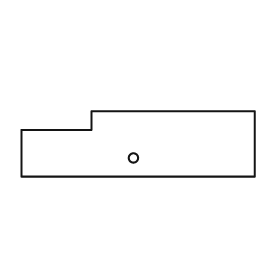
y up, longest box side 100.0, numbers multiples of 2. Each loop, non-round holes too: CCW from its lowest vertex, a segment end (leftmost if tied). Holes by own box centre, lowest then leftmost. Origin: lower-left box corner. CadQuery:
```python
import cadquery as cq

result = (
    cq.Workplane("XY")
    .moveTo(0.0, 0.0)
    .lineTo(100.0, 0.0)
    .lineTo(100.0, 28.0)
    .lineTo(30.0, 28.0)
    .lineTo(30.0, 20.0)
    .lineTo(0.0, 20.0)
    .close()
    .moveTo(48.0, 8.0)
    .circle(2.0)
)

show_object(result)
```